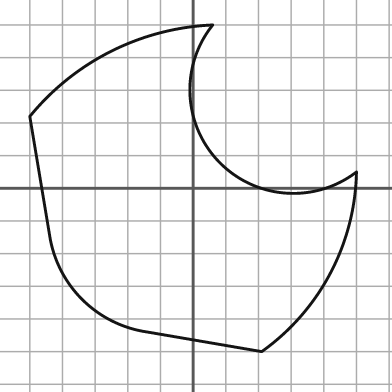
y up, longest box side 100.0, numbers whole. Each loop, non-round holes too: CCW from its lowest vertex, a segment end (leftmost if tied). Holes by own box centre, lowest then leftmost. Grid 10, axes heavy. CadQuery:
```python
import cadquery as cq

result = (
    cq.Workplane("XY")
    .moveTo(21.0, -50.0)
    .threePointArc((42.0, -26.0), (50.0, 5.0))
    .threePointArc((8.0, 8.0), (6.0, 50.0))
    .threePointArc((-25.0, 42.0), (-50.0, 22.0))
    .lineTo(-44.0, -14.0)
    .threePointArc((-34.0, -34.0), (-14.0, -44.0))
    .close()
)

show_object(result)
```